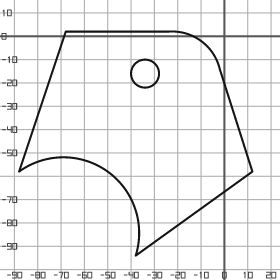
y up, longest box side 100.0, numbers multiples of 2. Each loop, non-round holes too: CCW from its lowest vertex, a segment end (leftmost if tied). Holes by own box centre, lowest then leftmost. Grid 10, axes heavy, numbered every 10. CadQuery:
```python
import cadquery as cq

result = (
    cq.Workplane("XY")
    .moveTo(-38.0, -94.0)
    .lineTo(12.0, -58.0)
    .lineTo(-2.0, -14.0)
    .threePointArc((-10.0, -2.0), (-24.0, 2.0))
    .lineTo(-68.0, 2.0)
    .lineTo(-88.0, -58.0)
    .threePointArc((-50.0, -58.0), (-38.0, -94.0))
    .close()
    .moveTo(-34.0, -16.0)
    .circle(6.0)
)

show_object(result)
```